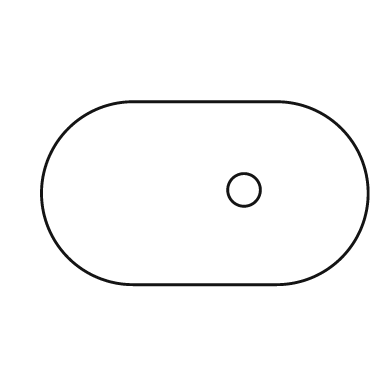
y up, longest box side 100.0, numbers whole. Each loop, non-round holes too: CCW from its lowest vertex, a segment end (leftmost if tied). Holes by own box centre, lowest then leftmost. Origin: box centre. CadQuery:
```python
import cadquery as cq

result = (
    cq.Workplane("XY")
    .moveTo(-22.0, -28.0)
    .lineTo(22.0, -28.0)
    .threePointArc((50.0, 0.0), (22.0, 28.0))
    .lineTo(-22.0, 28.0)
    .threePointArc((-50.0, 0.0), (-22.0, -28.0))
    .close()
    .moveTo(12.0, 1.0)
    .circle(5.0)
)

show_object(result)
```